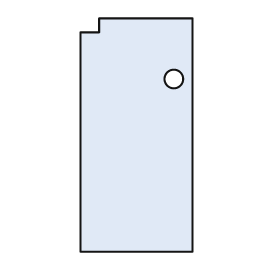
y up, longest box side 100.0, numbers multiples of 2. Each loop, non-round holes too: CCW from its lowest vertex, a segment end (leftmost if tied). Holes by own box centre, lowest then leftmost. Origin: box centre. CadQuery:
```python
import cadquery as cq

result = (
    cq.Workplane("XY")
    .moveTo(-24.0, -50.0)
    .lineTo(24.0, -50.0)
    .lineTo(24.0, 50.0)
    .lineTo(-16.0, 50.0)
    .lineTo(-16.0, 44.0)
    .lineTo(-24.0, 44.0)
    .close()
    .moveTo(16.0, 24.0)
    .circle(4.0)
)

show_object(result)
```